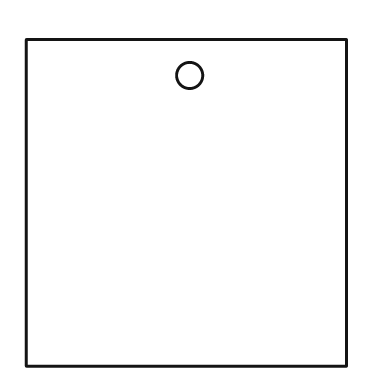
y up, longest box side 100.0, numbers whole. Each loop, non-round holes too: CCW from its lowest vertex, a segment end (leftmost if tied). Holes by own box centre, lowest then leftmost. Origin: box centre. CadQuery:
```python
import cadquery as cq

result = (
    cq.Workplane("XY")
    .moveTo(-49.0, -50.0)
    .lineTo(49.0, -50.0)
    .lineTo(49.0, 50.0)
    .lineTo(-49.0, 50.0)
    .close()
    .moveTo(1.0, 39.0)
    .circle(4.0)
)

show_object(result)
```